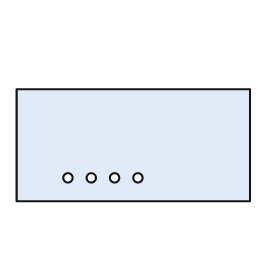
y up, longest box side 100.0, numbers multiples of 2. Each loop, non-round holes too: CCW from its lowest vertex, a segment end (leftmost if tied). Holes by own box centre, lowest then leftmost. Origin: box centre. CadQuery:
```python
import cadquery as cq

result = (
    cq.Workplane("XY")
    .moveTo(-50.0, -24.0)
    .lineTo(50.0, -24.0)
    .lineTo(50.0, 24.0)
    .lineTo(-50.0, 24.0)
    .close()
    .moveTo(-28.0, -14.0)
    .circle(2.0)
    .moveTo(-18.0, -14.0)
    .circle(2.0)
    .moveTo(-8.0, -14.0)
    .circle(2.0)
    .moveTo(2.0, -14.0)
    .circle(2.0)
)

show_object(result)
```